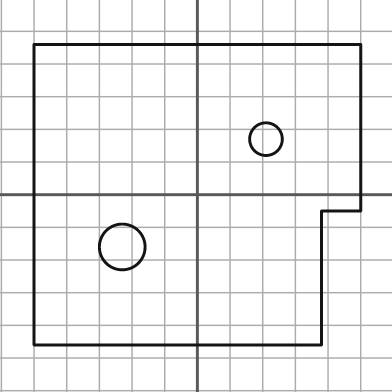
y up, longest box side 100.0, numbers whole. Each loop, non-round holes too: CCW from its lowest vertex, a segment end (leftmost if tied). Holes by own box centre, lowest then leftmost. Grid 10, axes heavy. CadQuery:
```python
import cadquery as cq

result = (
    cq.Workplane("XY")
    .moveTo(-50.0, -46.0)
    .lineTo(38.0, -46.0)
    .lineTo(38.0, -5.0)
    .lineTo(50.0, -5.0)
    .lineTo(50.0, 46.0)
    .lineTo(-50.0, 46.0)
    .close()
    .moveTo(-23.0, -16.0)
    .circle(7.0)
    .moveTo(21.0, 17.0)
    .circle(5.0)
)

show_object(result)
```